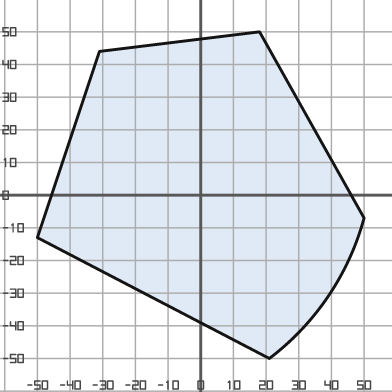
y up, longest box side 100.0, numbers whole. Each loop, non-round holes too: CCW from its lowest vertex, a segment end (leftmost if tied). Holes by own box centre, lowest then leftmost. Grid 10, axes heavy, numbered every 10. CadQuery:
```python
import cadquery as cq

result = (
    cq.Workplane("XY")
    .moveTo(21.0, -50.0)
    .threePointArc((39.0, -31.0), (50.0, -7.0))
    .lineTo(18.0, 50.0)
    .lineTo(-31.0, 44.0)
    .lineTo(-50.0, -13.0)
    .close()
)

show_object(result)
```